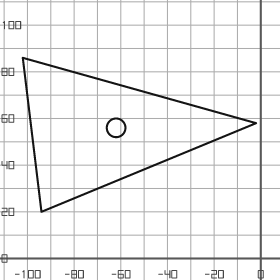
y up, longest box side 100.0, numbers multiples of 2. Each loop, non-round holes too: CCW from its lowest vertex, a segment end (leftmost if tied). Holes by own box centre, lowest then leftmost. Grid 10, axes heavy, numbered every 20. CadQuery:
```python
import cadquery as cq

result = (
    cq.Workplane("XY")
    .moveTo(-94.0, 20.0)
    .lineTo(-2.0, 58.0)
    .lineTo(-102.0, 86.0)
    .close()
    .moveTo(-62.0, 56.0)
    .circle(4.0)
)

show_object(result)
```